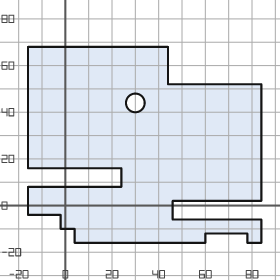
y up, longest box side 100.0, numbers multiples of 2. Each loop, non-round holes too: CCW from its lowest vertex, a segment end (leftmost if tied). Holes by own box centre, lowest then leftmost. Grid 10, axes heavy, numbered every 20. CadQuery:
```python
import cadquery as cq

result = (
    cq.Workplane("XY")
    .moveTo(4.0, -16.0)
    .lineTo(60.0, -16.0)
    .lineTo(60.0, -12.0)
    .lineTo(78.0, -12.0)
    .lineTo(78.0, -16.0)
    .lineTo(84.0, -16.0)
    .lineTo(84.0, -6.0)
    .lineTo(46.0, -6.0)
    .lineTo(46.0, 2.0)
    .lineTo(84.0, 2.0)
    .lineTo(84.0, 52.0)
    .lineTo(44.0, 52.0)
    .lineTo(44.0, 68.0)
    .lineTo(-16.0, 68.0)
    .lineTo(-16.0, 16.0)
    .lineTo(24.0, 16.0)
    .lineTo(24.0, 8.0)
    .lineTo(-16.0, 8.0)
    .lineTo(-16.0, -4.0)
    .lineTo(-2.0, -4.0)
    .lineTo(-2.0, -10.0)
    .lineTo(4.0, -10.0)
    .close()
    .moveTo(30.0, 44.0)
    .circle(4.0)
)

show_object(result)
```